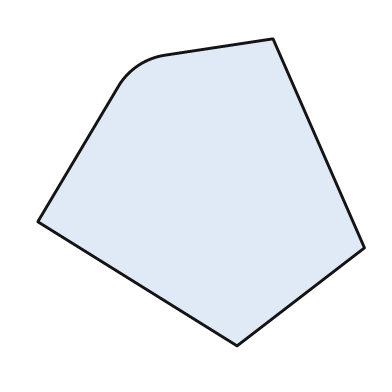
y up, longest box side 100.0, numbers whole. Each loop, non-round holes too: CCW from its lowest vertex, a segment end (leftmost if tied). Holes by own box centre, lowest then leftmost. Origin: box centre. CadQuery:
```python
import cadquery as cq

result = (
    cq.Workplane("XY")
    .moveTo(11.0, -47.0)
    .lineTo(50.0, -17.0)
    .lineTo(22.0, 47.0)
    .lineTo(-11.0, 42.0)
    .threePointArc((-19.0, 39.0), (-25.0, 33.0))
    .lineTo(-50.0, -9.0)
    .close()
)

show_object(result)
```